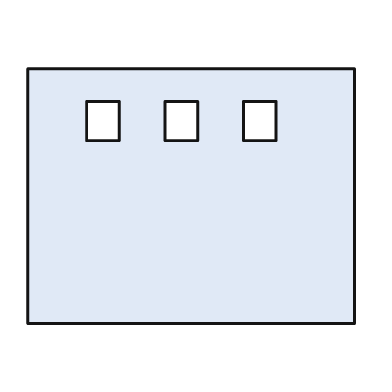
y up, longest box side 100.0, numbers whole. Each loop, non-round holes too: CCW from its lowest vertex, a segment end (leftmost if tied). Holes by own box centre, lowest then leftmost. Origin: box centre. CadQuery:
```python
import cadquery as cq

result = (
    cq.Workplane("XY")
    .moveTo(-50.0, -39.0)
    .lineTo(50.0, -39.0)
    .lineTo(50.0, 39.0)
    .lineTo(-50.0, 39.0)
    .close()
    .moveTo(-32.0, 17.0)
    .lineTo(-22.0, 17.0)
    .lineTo(-22.0, 29.0)
    .lineTo(-32.0, 29.0)
    .close()
    .moveTo(-8.0, 17.0)
    .lineTo(2.0, 17.0)
    .lineTo(2.0, 29.0)
    .lineTo(-8.0, 29.0)
    .close()
    .moveTo(16.0, 17.0)
    .lineTo(26.0, 17.0)
    .lineTo(26.0, 29.0)
    .lineTo(16.0, 29.0)
    .close()
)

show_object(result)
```